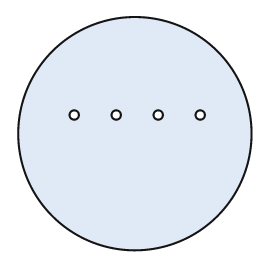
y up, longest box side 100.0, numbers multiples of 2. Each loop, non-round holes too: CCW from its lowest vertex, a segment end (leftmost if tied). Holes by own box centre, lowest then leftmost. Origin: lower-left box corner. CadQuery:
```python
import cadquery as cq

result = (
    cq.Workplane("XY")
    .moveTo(50.0, 50.0)
    .circle(50.0)
    .moveTo(24.0, 58.0)
    .circle(2.0)
    .moveTo(42.0, 58.0)
    .circle(2.0)
    .moveTo(60.0, 58.0)
    .circle(2.0)
    .moveTo(78.0, 58.0)
    .circle(2.0)
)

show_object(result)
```